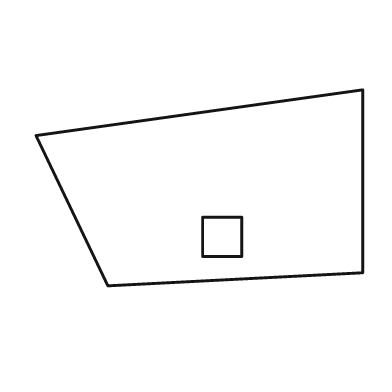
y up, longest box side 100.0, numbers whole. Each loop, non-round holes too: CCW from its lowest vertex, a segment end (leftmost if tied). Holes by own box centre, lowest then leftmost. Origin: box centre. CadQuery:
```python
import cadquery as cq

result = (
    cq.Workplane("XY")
    .moveTo(-28.0, -30.0)
    .lineTo(50.0, -26.0)
    .lineTo(50.0, 30.0)
    .lineTo(-50.0, 16.0)
    .close()
    .moveTo(1.0, -21.0)
    .lineTo(13.0, -21.0)
    .lineTo(13.0, -9.0)
    .lineTo(1.0, -9.0)
    .close()
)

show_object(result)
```